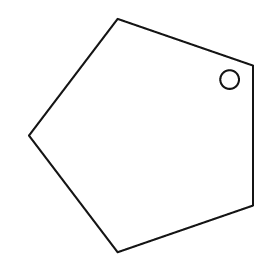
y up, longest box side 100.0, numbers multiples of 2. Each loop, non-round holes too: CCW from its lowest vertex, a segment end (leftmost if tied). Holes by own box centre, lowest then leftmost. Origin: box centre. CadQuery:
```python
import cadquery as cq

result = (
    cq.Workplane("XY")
    .moveTo(-10.0, -50.0)
    .lineTo(48.0, -30.0)
    .lineTo(48.0, 30.0)
    .lineTo(-10.0, 50.0)
    .lineTo(-48.0, 0.0)
    .close()
    .moveTo(38.0, 24.0)
    .circle(4.0)
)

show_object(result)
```